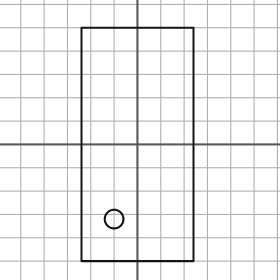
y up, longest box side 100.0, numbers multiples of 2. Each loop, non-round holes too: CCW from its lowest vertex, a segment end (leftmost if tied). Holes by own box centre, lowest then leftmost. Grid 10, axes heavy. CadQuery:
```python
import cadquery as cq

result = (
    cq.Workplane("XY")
    .moveTo(-24.0, -50.0)
    .lineTo(24.0, -50.0)
    .lineTo(24.0, 50.0)
    .lineTo(-24.0, 50.0)
    .close()
    .moveTo(-10.0, -32.0)
    .circle(4.0)
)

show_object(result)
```